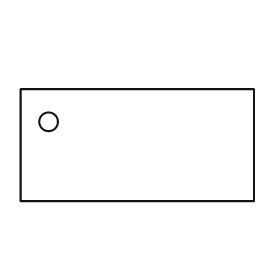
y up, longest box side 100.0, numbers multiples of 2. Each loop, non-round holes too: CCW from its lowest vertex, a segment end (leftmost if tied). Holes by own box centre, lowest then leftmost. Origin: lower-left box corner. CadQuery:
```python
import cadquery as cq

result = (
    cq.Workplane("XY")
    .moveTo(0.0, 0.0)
    .lineTo(100.0, 0.0)
    .lineTo(100.0, 48.0)
    .lineTo(0.0, 48.0)
    .close()
    .moveTo(12.0, 34.0)
    .circle(4.0)
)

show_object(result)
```